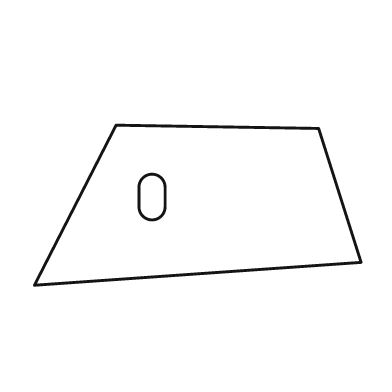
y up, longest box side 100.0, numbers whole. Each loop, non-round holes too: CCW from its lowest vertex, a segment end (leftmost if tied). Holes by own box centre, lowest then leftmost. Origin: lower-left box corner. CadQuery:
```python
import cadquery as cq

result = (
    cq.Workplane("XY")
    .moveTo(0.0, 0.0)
    .lineTo(100.0, 7.0)
    .lineTo(87.0, 48.0)
    .lineTo(25.0, 49.0)
    .close()
    .moveTo(32.0, 24.0)
    .threePointArc((36.0, 20.0), (40.0, 24.0))
    .lineTo(40.0, 30.0)
    .threePointArc((36.0, 34.0), (32.0, 30.0))
    .close()
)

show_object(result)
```